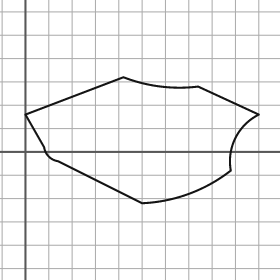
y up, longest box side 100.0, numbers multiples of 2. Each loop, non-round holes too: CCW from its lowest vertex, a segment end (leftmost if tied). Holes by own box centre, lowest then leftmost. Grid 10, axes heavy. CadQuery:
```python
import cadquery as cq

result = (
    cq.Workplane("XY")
    .moveTo(50.0, -22.0)
    .threePointArc((70.0, -18.0), (88.0, -8.0))
    .threePointArc((90.0, 6.0), (100.0, 16.0))
    .lineTo(74.0, 28.0)
    .threePointArc((58.0, 28.0), (42.0, 32.0))
    .lineTo(0.0, 16.0)
    .lineTo(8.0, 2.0)
    .threePointArc((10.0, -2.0), (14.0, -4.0))
    .close()
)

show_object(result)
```